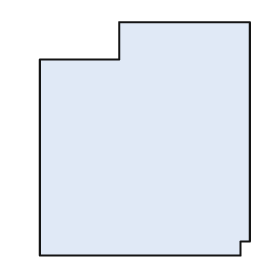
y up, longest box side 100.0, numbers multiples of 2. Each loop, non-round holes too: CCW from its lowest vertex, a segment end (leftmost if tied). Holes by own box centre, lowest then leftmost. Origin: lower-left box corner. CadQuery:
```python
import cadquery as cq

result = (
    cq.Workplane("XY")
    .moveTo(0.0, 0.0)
    .lineTo(86.0, 0.0)
    .lineTo(86.0, 6.0)
    .lineTo(90.0, 6.0)
    .lineTo(90.0, 100.0)
    .lineTo(34.0, 100.0)
    .lineTo(34.0, 84.0)
    .lineTo(0.0, 84.0)
    .close()
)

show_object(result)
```